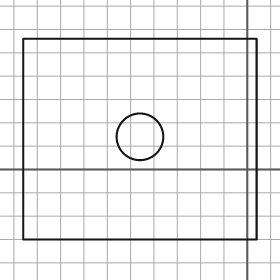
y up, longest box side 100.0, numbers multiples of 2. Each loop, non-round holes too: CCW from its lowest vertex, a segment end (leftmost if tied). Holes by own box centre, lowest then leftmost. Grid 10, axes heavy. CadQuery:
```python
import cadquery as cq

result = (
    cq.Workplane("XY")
    .moveTo(-96.0, -30.0)
    .lineTo(4.0, -30.0)
    .lineTo(4.0, 56.0)
    .lineTo(-96.0, 56.0)
    .close()
    .moveTo(-46.0, 14.0)
    .circle(10.0)
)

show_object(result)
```